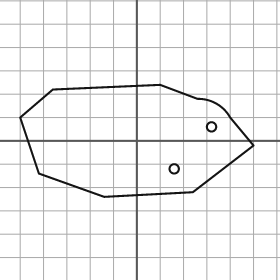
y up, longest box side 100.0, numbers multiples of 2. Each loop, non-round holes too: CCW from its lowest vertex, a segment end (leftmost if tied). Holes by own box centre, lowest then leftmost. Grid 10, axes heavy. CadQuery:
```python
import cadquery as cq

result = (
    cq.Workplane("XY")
    .moveTo(-14.0, -24.0)
    .lineTo(24.0, -22.0)
    .lineTo(50.0, -2.0)
    .lineTo(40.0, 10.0)
    .threePointArc((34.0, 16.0), (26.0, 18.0))
    .lineTo(10.0, 24.0)
    .lineTo(-36.0, 22.0)
    .lineTo(-50.0, 10.0)
    .lineTo(-42.0, -14.0)
    .close()
    .moveTo(16.0, -12.0)
    .circle(2.0)
    .moveTo(32.0, 6.0)
    .circle(2.0)
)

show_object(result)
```